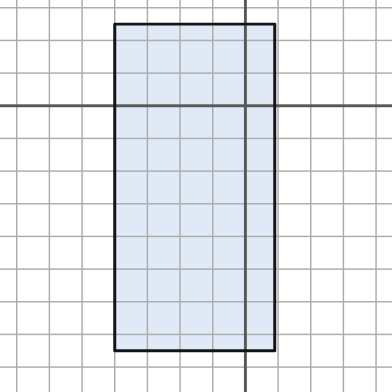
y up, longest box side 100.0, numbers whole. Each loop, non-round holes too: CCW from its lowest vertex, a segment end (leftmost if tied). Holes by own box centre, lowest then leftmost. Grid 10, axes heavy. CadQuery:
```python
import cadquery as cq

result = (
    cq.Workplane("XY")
    .moveTo(-40.0, -75.0)
    .lineTo(9.0, -75.0)
    .lineTo(9.0, 25.0)
    .lineTo(-40.0, 25.0)
    .close()
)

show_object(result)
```